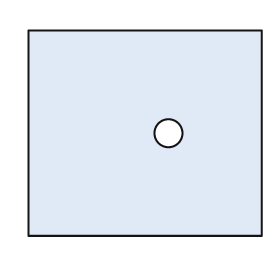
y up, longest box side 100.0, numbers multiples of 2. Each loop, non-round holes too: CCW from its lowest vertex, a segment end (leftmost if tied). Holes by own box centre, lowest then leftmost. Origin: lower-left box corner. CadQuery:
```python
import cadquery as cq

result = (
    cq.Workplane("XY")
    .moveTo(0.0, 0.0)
    .lineTo(100.0, 0.0)
    .lineTo(100.0, 88.0)
    .lineTo(0.0, 88.0)
    .close()
    .moveTo(60.0, 44.0)
    .circle(6.0)
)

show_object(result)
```